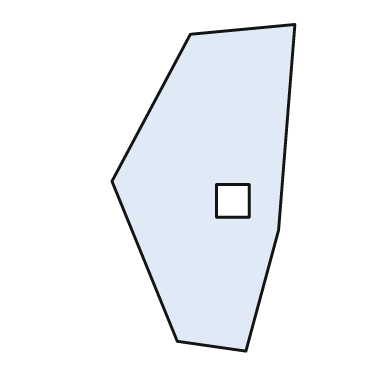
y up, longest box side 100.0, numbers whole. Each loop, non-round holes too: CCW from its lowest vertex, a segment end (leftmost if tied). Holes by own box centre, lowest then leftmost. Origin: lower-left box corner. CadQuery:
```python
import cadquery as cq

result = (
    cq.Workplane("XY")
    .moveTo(41.0, 0.0)
    .lineTo(51.0, 37.0)
    .lineTo(56.0, 100.0)
    .lineTo(24.0, 97.0)
    .lineTo(0.0, 52.0)
    .lineTo(20.0, 3.0)
    .close()
    .moveTo(32.0, 41.0)
    .lineTo(42.0, 41.0)
    .lineTo(42.0, 51.0)
    .lineTo(32.0, 51.0)
    .close()
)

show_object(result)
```